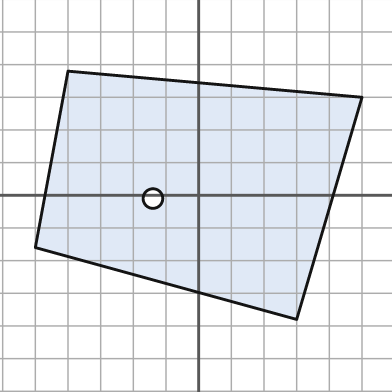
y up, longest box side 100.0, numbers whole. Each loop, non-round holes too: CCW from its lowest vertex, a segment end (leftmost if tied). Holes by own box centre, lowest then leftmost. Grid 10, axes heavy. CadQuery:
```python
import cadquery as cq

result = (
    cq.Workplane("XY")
    .moveTo(30.0, -38.0)
    .lineTo(50.0, 30.0)
    .lineTo(-40.0, 38.0)
    .lineTo(-50.0, -16.0)
    .close()
    .moveTo(-14.0, -1.0)
    .circle(3.0)
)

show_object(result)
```